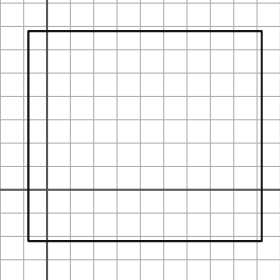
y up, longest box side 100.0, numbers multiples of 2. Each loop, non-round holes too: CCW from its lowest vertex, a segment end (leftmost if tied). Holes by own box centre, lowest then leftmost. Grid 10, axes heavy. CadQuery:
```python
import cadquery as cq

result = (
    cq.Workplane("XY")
    .moveTo(-8.0, -22.0)
    .lineTo(92.0, -22.0)
    .lineTo(92.0, 68.0)
    .lineTo(-8.0, 68.0)
    .close()
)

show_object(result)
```